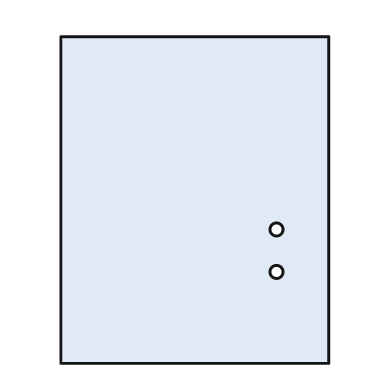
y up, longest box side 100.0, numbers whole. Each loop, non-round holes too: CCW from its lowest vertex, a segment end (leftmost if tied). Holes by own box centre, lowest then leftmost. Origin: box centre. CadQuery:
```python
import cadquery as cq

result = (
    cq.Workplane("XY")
    .moveTo(-41.0, -50.0)
    .lineTo(41.0, -50.0)
    .lineTo(41.0, 50.0)
    .lineTo(-41.0, 50.0)
    .close()
    .moveTo(25.0, -22.0)
    .circle(2.0)
    .moveTo(25.0, -9.0)
    .circle(2.0)
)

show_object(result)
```